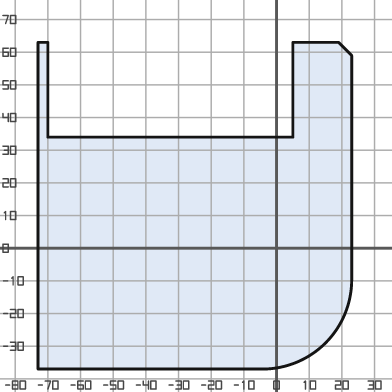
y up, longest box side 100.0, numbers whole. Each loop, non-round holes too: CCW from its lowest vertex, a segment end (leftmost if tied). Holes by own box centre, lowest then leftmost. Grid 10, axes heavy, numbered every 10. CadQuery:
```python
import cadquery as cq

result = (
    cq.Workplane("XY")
    .moveTo(-73.0, -37.0)
    .lineTo(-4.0, -37.0)
    .threePointArc((15.0, -29.0), (23.0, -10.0))
    .lineTo(23.0, 59.0)
    .lineTo(19.0, 63.0)
    .lineTo(5.0, 63.0)
    .lineTo(5.0, 34.0)
    .lineTo(-70.0, 34.0)
    .lineTo(-70.0, 63.0)
    .lineTo(-73.0, 63.0)
    .close()
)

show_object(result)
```